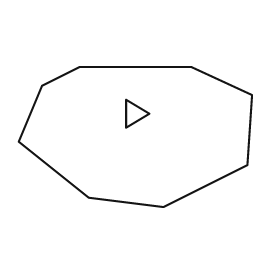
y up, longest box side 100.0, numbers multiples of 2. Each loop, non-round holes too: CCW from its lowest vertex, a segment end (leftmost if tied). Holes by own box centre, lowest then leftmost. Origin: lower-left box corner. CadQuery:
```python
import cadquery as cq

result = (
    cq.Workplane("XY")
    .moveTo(62.0, 0.0)
    .lineTo(98.0, 18.0)
    .lineTo(100.0, 48.0)
    .lineTo(74.0, 60.0)
    .lineTo(26.0, 60.0)
    .lineTo(10.0, 52.0)
    .lineTo(0.0, 28.0)
    .lineTo(30.0, 4.0)
    .close()
    .moveTo(46.0, 34.0)
    .lineTo(56.0, 40.0)
    .lineTo(46.0, 46.0)
    .close()
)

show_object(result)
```